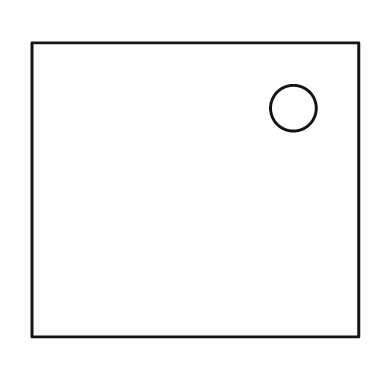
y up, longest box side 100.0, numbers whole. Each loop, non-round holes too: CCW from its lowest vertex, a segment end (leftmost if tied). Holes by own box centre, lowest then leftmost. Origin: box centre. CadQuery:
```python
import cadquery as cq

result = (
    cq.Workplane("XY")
    .moveTo(-50.0, -45.0)
    .lineTo(50.0, -45.0)
    .lineTo(50.0, 45.0)
    .lineTo(-50.0, 45.0)
    .close()
    .moveTo(30.0, 25.0)
    .circle(7.0)
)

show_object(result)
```